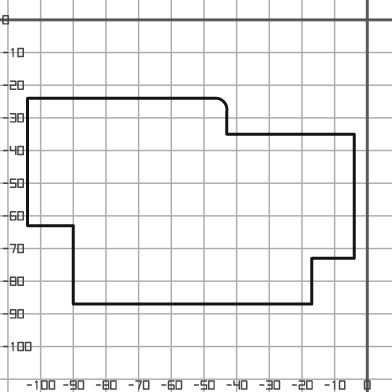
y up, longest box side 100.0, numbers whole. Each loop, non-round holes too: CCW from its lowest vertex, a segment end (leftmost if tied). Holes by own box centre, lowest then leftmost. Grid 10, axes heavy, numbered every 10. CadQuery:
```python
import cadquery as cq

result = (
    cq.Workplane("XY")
    .moveTo(-90.0, -87.0)
    .lineTo(-17.0, -87.0)
    .lineTo(-17.0, -73.0)
    .lineTo(-4.0, -73.0)
    .lineTo(-4.0, -35.0)
    .lineTo(-43.0, -35.0)
    .lineTo(-43.0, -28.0)
    .threePointArc((-44.0, -25.0), (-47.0, -24.0))
    .lineTo(-104.0, -24.0)
    .lineTo(-104.0, -63.0)
    .lineTo(-90.0, -63.0)
    .close()
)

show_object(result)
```